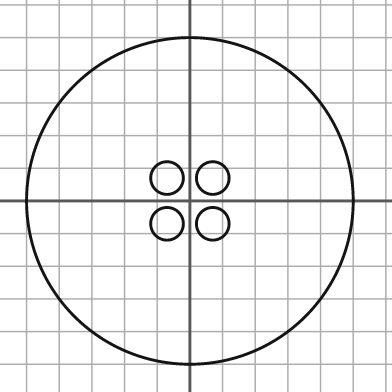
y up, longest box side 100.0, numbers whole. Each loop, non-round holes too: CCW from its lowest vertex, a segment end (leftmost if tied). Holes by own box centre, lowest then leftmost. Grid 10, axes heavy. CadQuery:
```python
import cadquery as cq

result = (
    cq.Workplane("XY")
    .moveTo(0.0, 0.0)
    .circle(50.0)
    .moveTo(-7.0, -7.0)
    .circle(5.0)
    .moveTo(7.0, -7.0)
    .circle(5.0)
    .moveTo(-7.0, 7.0)
    .circle(5.0)
    .moveTo(7.0, 7.0)
    .circle(5.0)
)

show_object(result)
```